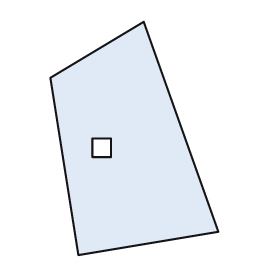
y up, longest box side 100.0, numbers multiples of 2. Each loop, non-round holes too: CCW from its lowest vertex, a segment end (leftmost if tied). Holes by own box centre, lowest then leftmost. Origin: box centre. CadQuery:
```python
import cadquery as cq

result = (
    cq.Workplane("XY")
    .moveTo(-24.0, -50.0)
    .lineTo(36.0, -40.0)
    .lineTo(4.0, 50.0)
    .lineTo(-36.0, 26.0)
    .close()
    .moveTo(-18.0, -8.0)
    .lineTo(-10.0, -8.0)
    .lineTo(-10.0, 0.0)
    .lineTo(-18.0, 0.0)
    .close()
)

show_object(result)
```